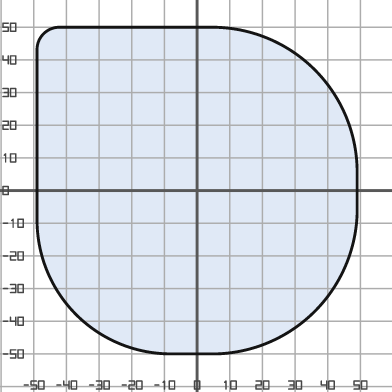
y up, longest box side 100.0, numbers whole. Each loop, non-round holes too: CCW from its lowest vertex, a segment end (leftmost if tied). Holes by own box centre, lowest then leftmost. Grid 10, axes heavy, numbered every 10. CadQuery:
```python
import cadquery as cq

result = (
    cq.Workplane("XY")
    .moveTo(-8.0, -50.0)
    .lineTo(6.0, -50.0)
    .threePointArc((36.0, -37.0), (49.0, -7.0))
    .lineTo(49.0, 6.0)
    .threePointArc((36.0, 37.0), (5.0, 50.0))
    .lineTo(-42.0, 50.0)
    .threePointArc((-47.0, 48.0), (-49.0, 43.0))
    .lineTo(-49.0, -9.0)
    .threePointArc((-37.0, -38.0), (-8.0, -50.0))
    .close()
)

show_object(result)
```